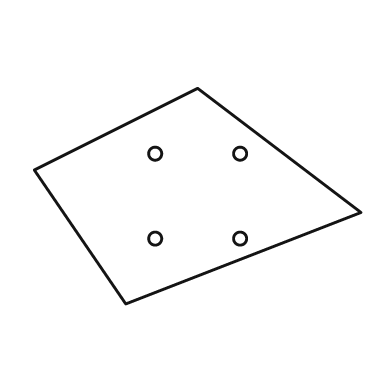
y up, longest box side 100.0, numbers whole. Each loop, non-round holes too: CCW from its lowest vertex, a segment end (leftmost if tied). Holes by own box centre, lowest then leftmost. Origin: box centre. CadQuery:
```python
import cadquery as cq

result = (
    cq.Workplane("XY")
    .moveTo(-22.0, -33.0)
    .lineTo(50.0, -5.0)
    .lineTo(0.0, 33.0)
    .lineTo(-50.0, 8.0)
    .close()
    .moveTo(-13.0, -13.0)
    .circle(2.0)
    .moveTo(13.0, -13.0)
    .circle(2.0)
    .moveTo(-13.0, 13.0)
    .circle(2.0)
    .moveTo(13.0, 13.0)
    .circle(2.0)
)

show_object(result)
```